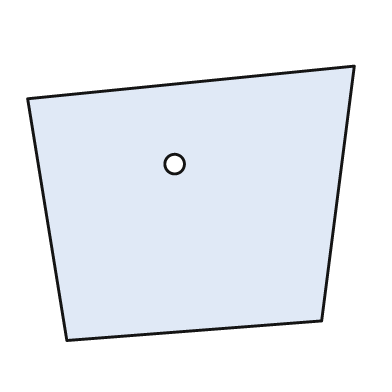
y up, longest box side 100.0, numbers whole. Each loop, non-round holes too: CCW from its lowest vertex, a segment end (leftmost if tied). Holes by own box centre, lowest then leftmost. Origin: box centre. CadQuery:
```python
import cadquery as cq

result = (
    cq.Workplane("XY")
    .moveTo(-38.0, -42.0)
    .lineTo(40.0, -36.0)
    .lineTo(50.0, 42.0)
    .lineTo(-50.0, 32.0)
    .close()
    .moveTo(-5.0, 12.0)
    .circle(3.0)
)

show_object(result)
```